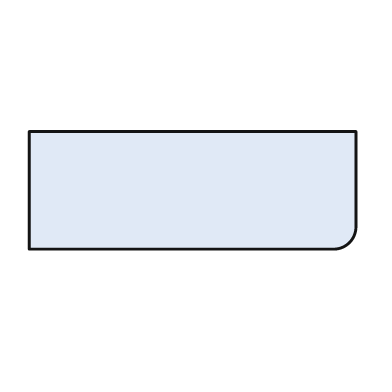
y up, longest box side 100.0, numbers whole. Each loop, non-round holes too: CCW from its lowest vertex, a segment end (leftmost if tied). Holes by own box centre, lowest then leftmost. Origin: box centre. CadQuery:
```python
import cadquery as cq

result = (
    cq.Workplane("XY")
    .moveTo(-50.0, -18.0)
    .lineTo(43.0, -18.0)
    .threePointArc((48.0, -16.0), (50.0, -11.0))
    .lineTo(50.0, 18.0)
    .lineTo(-50.0, 18.0)
    .close()
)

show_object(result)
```